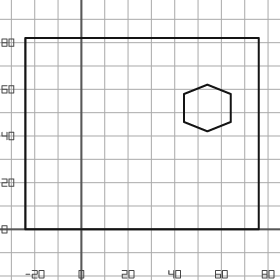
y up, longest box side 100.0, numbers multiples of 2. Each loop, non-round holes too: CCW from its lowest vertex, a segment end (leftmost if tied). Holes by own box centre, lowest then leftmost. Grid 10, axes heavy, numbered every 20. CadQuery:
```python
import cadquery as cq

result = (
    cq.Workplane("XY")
    .moveTo(-24.0, 0.0)
    .lineTo(76.0, 0.0)
    .lineTo(76.0, 82.0)
    .lineTo(-24.0, 82.0)
    .close()
    .moveTo(54.0, 42.0)
    .lineTo(64.0, 46.0)
    .lineTo(64.0, 58.0)
    .lineTo(54.0, 62.0)
    .lineTo(44.0, 58.0)
    .lineTo(44.0, 46.0)
    .close()
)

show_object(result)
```